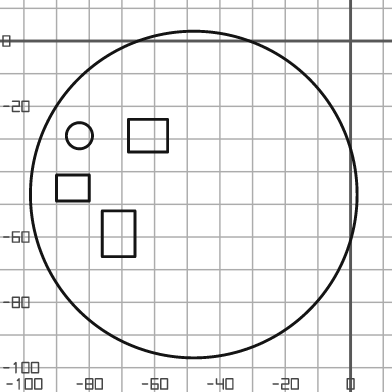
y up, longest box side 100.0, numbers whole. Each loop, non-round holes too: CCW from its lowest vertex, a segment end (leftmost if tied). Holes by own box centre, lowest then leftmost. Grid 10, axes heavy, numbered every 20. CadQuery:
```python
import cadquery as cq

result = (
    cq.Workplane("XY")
    .moveTo(-48.0, -47.0)
    .circle(50.0)
    .moveTo(-76.0, -66.0)
    .lineTo(-66.0, -66.0)
    .lineTo(-66.0, -52.0)
    .lineTo(-76.0, -52.0)
    .close()
    .moveTo(-90.0, -49.0)
    .lineTo(-80.0, -49.0)
    .lineTo(-80.0, -41.0)
    .lineTo(-90.0, -41.0)
    .close()
    .moveTo(-83.0, -29.0)
    .circle(4.0)
    .moveTo(-68.0, -34.0)
    .lineTo(-56.0, -34.0)
    .lineTo(-56.0, -24.0)
    .lineTo(-68.0, -24.0)
    .close()
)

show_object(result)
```